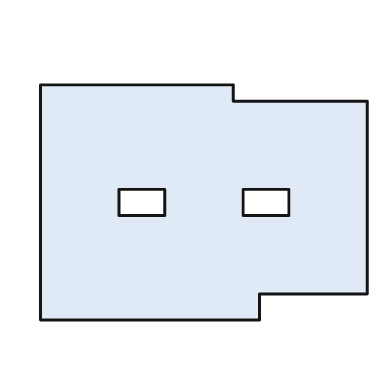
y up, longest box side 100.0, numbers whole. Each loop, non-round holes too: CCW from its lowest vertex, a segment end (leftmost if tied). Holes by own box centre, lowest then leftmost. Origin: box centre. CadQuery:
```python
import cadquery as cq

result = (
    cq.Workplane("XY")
    .moveTo(-50.0, -36.0)
    .lineTo(17.0, -36.0)
    .lineTo(17.0, -28.0)
    .lineTo(50.0, -28.0)
    .lineTo(50.0, 31.0)
    .lineTo(9.0, 31.0)
    .lineTo(9.0, 36.0)
    .lineTo(-50.0, 36.0)
    .close()
    .moveTo(-26.0, -4.0)
    .lineTo(-12.0, -4.0)
    .lineTo(-12.0, 4.0)
    .lineTo(-26.0, 4.0)
    .close()
    .moveTo(12.0, -4.0)
    .lineTo(26.0, -4.0)
    .lineTo(26.0, 4.0)
    .lineTo(12.0, 4.0)
    .close()
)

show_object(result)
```